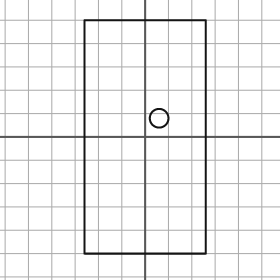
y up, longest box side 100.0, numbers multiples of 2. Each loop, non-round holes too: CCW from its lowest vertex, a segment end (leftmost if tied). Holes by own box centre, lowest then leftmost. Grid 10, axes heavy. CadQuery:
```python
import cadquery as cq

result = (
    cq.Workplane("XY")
    .moveTo(-26.0, -50.0)
    .lineTo(26.0, -50.0)
    .lineTo(26.0, 50.0)
    .lineTo(-26.0, 50.0)
    .close()
    .moveTo(6.0, 8.0)
    .circle(4.0)
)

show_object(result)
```